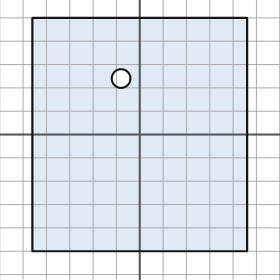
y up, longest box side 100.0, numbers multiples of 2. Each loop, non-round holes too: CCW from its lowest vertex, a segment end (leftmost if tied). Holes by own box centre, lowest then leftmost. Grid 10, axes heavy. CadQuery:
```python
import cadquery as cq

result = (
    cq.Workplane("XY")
    .moveTo(-46.0, -50.0)
    .lineTo(46.0, -50.0)
    .lineTo(46.0, 50.0)
    .lineTo(-46.0, 50.0)
    .close()
    .moveTo(-8.0, 24.0)
    .circle(4.0)
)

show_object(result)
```